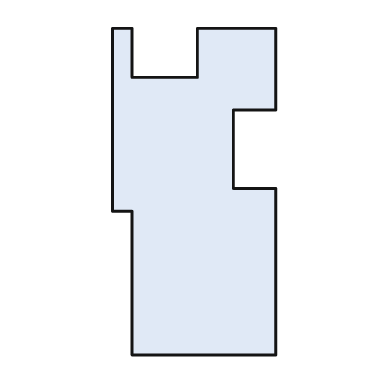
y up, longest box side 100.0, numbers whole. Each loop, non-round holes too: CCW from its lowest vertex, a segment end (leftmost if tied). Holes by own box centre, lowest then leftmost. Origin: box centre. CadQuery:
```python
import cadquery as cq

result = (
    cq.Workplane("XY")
    .moveTo(-19.0, -50.0)
    .lineTo(25.0, -50.0)
    .lineTo(25.0, 1.0)
    .lineTo(12.0, 1.0)
    .lineTo(12.0, 25.0)
    .lineTo(25.0, 25.0)
    .lineTo(25.0, 50.0)
    .lineTo(1.0, 50.0)
    .lineTo(1.0, 35.0)
    .lineTo(-19.0, 35.0)
    .lineTo(-19.0, 50.0)
    .lineTo(-25.0, 50.0)
    .lineTo(-25.0, -6.0)
    .lineTo(-19.0, -6.0)
    .close()
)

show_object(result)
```